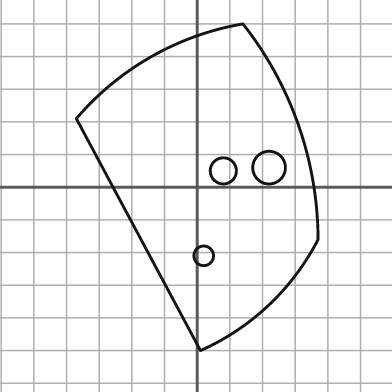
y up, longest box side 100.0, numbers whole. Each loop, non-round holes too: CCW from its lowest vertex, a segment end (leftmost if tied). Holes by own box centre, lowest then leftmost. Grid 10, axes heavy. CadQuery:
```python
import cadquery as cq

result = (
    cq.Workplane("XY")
    .moveTo(1.0, -50.0)
    .threePointArc((22.0, -36.0), (37.0, -16.0))
    .threePointArc((31.0, 19.0), (14.0, 50.0))
    .threePointArc((-14.0, 40.0), (-37.0, 21.0))
    .close()
    .moveTo(2.0, -21.0)
    .circle(3.0)
    .moveTo(8.0, 5.0)
    .circle(4.0)
    .moveTo(22.0, 6.0)
    .circle(5.0)
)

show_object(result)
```